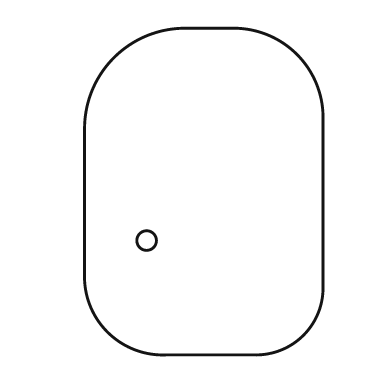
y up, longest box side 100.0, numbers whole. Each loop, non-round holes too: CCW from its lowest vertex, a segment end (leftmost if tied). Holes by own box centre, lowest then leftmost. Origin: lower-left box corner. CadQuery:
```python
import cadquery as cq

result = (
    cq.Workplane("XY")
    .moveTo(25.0, 0.0)
    .lineTo(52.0, 0.0)
    .threePointArc((67.0, 6.0), (73.0, 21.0))
    .lineTo(73.0, 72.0)
    .threePointArc((65.0, 92.0), (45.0, 100.0))
    .lineTo(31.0, 100.0)
    .threePointArc((9.0, 91.0), (0.0, 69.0))
    .lineTo(0.0, 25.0)
    .threePointArc((7.0, 7.0), (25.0, 0.0))
    .close()
    .moveTo(19.0, 35.0)
    .circle(3.0)
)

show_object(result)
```